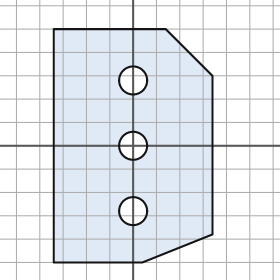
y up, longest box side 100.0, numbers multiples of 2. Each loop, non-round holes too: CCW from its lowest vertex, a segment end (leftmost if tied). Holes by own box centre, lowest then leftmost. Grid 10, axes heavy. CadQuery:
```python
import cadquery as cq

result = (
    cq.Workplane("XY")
    .moveTo(-34.0, -50.0)
    .lineTo(4.0, -50.0)
    .lineTo(34.0, -38.0)
    .lineTo(34.0, 30.0)
    .lineTo(14.0, 50.0)
    .lineTo(-34.0, 50.0)
    .close()
    .moveTo(0.0, -28.0)
    .circle(6.0)
    .moveTo(0.0, 0.0)
    .circle(6.0)
    .moveTo(0.0, 28.0)
    .circle(6.0)
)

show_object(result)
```